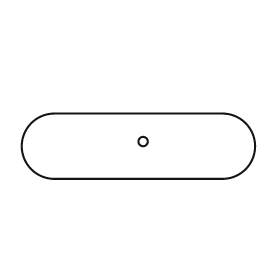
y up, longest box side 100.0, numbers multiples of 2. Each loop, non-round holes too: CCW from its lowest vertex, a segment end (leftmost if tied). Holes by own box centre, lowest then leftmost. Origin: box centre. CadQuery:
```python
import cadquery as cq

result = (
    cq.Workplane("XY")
    .moveTo(-36.0, -14.0)
    .lineTo(36.0, -14.0)
    .threePointArc((50.0, 0.0), (36.0, 14.0))
    .lineTo(-36.0, 14.0)
    .threePointArc((-50.0, 0.0), (-36.0, -14.0))
    .close()
    .moveTo(2.0, 2.0)
    .circle(2.0)
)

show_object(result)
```